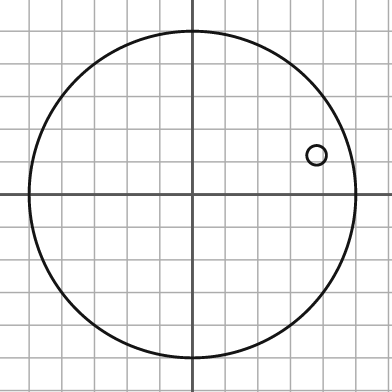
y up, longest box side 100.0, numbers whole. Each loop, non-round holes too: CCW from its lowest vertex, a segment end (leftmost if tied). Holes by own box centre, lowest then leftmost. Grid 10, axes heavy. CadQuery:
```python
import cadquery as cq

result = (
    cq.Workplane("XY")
    .moveTo(0.0, 0.0)
    .circle(50.0)
    .moveTo(38.0, 12.0)
    .circle(3.0)
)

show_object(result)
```